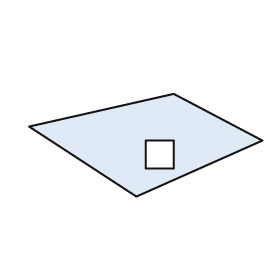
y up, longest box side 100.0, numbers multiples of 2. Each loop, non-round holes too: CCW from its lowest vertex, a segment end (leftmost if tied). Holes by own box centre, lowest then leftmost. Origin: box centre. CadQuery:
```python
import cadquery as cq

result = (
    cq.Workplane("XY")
    .moveTo(-4.0, -22.0)
    .lineTo(50.0, 2.0)
    .lineTo(12.0, 22.0)
    .lineTo(-50.0, 8.0)
    .close()
    .moveTo(0.0, -10.0)
    .lineTo(12.0, -10.0)
    .lineTo(12.0, 2.0)
    .lineTo(0.0, 2.0)
    .close()
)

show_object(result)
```